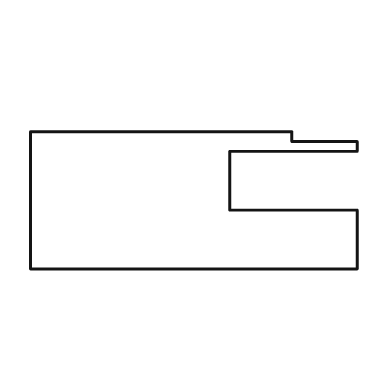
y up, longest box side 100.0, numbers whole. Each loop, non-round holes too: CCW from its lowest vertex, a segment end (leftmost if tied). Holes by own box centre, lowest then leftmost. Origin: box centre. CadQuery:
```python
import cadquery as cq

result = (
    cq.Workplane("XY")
    .moveTo(-50.0, -21.0)
    .lineTo(50.0, -21.0)
    .lineTo(50.0, -3.0)
    .lineTo(11.0, -3.0)
    .lineTo(11.0, 15.0)
    .lineTo(50.0, 15.0)
    .lineTo(50.0, 18.0)
    .lineTo(30.0, 18.0)
    .lineTo(30.0, 21.0)
    .lineTo(-50.0, 21.0)
    .close()
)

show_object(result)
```